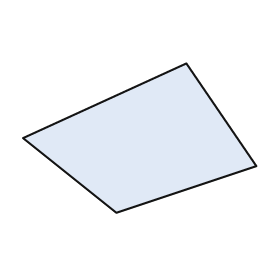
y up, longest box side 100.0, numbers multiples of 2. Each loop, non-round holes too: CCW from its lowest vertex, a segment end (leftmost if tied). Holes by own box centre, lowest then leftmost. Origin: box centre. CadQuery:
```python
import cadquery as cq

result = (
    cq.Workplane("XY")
    .moveTo(-10.0, -32.0)
    .lineTo(50.0, -12.0)
    .lineTo(20.0, 32.0)
    .lineTo(-50.0, 0.0)
    .close()
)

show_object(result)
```